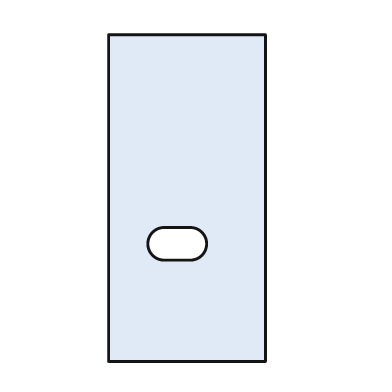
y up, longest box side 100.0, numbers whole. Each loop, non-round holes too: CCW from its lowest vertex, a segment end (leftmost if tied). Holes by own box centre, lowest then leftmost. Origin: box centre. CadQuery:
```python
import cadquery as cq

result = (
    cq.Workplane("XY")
    .moveTo(-24.0, -50.0)
    .lineTo(24.0, -50.0)
    .lineTo(24.0, 50.0)
    .lineTo(-24.0, 50.0)
    .close()
    .moveTo(-7.0, -19.0)
    .lineTo(1.0, -19.0)
    .threePointArc((6.0, -14.0), (1.0, -9.0))
    .lineTo(-7.0, -9.0)
    .threePointArc((-12.0, -14.0), (-7.0, -19.0))
    .close()
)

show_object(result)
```